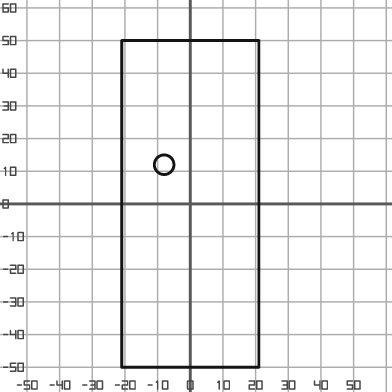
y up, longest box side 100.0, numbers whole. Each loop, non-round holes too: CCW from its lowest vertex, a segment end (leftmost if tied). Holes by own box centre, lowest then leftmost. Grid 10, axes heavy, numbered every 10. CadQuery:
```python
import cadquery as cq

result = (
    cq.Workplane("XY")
    .moveTo(-21.0, -50.0)
    .lineTo(21.0, -50.0)
    .lineTo(21.0, 50.0)
    .lineTo(-21.0, 50.0)
    .close()
    .moveTo(-8.0, 12.0)
    .circle(3.0)
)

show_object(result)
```